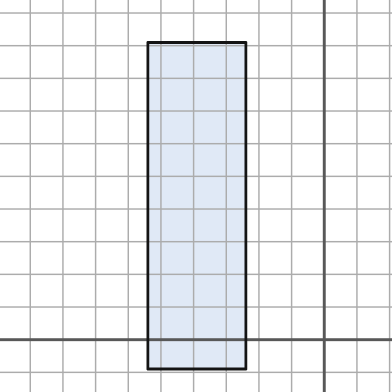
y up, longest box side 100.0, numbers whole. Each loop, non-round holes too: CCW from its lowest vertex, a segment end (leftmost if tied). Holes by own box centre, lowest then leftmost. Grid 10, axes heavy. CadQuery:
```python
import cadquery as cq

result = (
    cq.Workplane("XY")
    .moveTo(-54.0, -9.0)
    .lineTo(-24.0, -9.0)
    .lineTo(-24.0, 91.0)
    .lineTo(-54.0, 91.0)
    .close()
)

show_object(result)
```